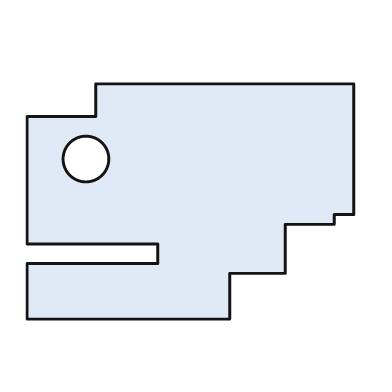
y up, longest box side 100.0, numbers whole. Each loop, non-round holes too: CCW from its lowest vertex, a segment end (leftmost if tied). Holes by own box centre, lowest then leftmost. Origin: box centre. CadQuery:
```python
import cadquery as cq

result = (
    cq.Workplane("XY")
    .moveTo(-50.0, -36.0)
    .lineTo(12.0, -36.0)
    .lineTo(12.0, -22.0)
    .lineTo(29.0, -22.0)
    .lineTo(29.0, -7.0)
    .lineTo(44.0, -7.0)
    .lineTo(44.0, -4.0)
    .lineTo(50.0, -4.0)
    .lineTo(50.0, 36.0)
    .lineTo(-29.0, 36.0)
    .lineTo(-29.0, 26.0)
    .lineTo(-50.0, 26.0)
    .lineTo(-50.0, -13.0)
    .lineTo(-10.0, -13.0)
    .lineTo(-10.0, -19.0)
    .lineTo(-50.0, -19.0)
    .close()
    .moveTo(-32.0, 13.0)
    .circle(7.0)
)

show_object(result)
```